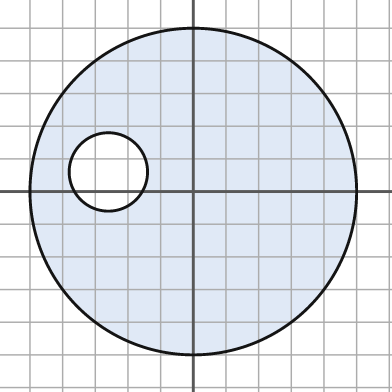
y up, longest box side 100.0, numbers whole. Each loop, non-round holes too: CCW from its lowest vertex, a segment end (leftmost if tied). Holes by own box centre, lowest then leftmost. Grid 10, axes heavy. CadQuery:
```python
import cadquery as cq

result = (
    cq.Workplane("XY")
    .moveTo(0.0, 0.0)
    .circle(50.0)
    .moveTo(-26.0, 6.0)
    .circle(12.0)
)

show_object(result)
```